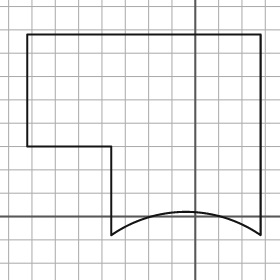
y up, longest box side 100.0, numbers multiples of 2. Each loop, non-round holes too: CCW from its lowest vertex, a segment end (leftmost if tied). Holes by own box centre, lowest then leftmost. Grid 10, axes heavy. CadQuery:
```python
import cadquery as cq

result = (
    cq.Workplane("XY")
    .moveTo(-36.0, -8.0)
    .threePointArc((-4.0, 2.0), (28.0, -8.0))
    .lineTo(28.0, 78.0)
    .lineTo(-72.0, 78.0)
    .lineTo(-72.0, 30.0)
    .lineTo(-36.0, 30.0)
    .close()
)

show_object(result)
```